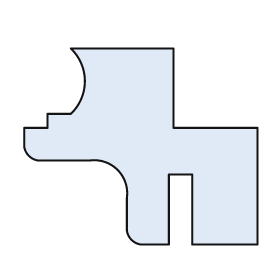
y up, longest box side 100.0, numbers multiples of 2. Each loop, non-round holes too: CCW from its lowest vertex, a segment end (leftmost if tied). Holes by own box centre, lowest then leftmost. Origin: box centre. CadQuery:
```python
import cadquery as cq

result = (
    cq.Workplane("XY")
    .moveTo(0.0, -42.0)
    .lineTo(12.0, -42.0)
    .lineTo(12.0, -12.0)
    .lineTo(22.0, -12.0)
    .lineTo(22.0, -42.0)
    .lineTo(50.0, -42.0)
    .lineTo(50.0, 8.0)
    .lineTo(14.0, 8.0)
    .lineTo(14.0, 42.0)
    .lineTo(-30.0, 42.0)
    .threePointArc((-24.0, 28.0), (-30.0, 14.0))
    .lineTo(-40.0, 14.0)
    .lineTo(-40.0, 8.0)
    .lineTo(-50.0, 8.0)
    .lineTo(-50.0, 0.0)
    .threePointArc((-48.0, -4.0), (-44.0, -6.0))
    .lineTo(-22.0, -6.0)
    .threePointArc((-10.0, -10.0), (-6.0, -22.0))
    .lineTo(-6.0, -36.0)
    .threePointArc((-4.0, -40.0), (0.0, -42.0))
    .close()
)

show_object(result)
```